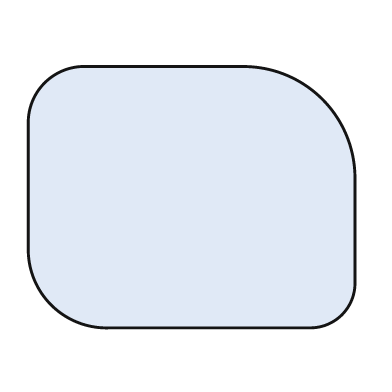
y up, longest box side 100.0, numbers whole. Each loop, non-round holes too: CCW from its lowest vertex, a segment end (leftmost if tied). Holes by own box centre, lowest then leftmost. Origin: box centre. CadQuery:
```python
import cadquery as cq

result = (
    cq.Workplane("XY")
    .moveTo(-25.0, -40.0)
    .lineTo(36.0, -40.0)
    .threePointArc((46.0, -36.0), (50.0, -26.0))
    .lineTo(50.0, 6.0)
    .threePointArc((40.0, 30.0), (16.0, 40.0))
    .lineTo(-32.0, 40.0)
    .threePointArc((-45.0, 35.0), (-50.0, 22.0))
    .lineTo(-50.0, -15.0)
    .threePointArc((-43.0, -33.0), (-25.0, -40.0))
    .close()
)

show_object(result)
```